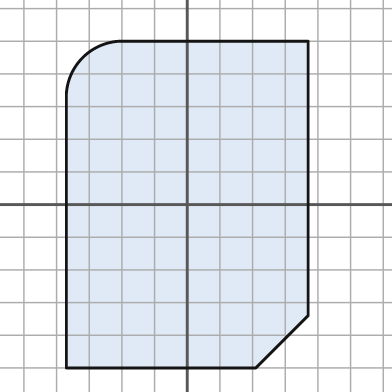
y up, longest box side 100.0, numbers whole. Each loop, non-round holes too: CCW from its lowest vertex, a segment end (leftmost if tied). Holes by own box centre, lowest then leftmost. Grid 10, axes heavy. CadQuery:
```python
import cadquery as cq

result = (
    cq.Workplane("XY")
    .moveTo(-37.0, -50.0)
    .lineTo(21.0, -50.0)
    .lineTo(37.0, -34.0)
    .lineTo(37.0, 50.0)
    .lineTo(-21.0, 50.0)
    .threePointArc((-32.0, 45.0), (-37.0, 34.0))
    .close()
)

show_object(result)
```